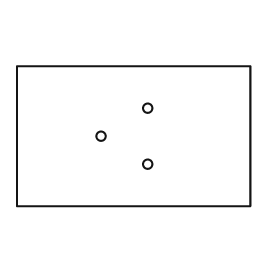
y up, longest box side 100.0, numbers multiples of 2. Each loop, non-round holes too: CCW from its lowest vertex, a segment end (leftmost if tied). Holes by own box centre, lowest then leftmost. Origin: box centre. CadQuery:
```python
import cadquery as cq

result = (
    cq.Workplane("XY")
    .moveTo(-50.0, -30.0)
    .lineTo(50.0, -30.0)
    .lineTo(50.0, 30.0)
    .lineTo(-50.0, 30.0)
    .close()
    .moveTo(6.0, -12.0)
    .circle(2.0)
    .moveTo(-14.0, 0.0)
    .circle(2.0)
    .moveTo(6.0, 12.0)
    .circle(2.0)
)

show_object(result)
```